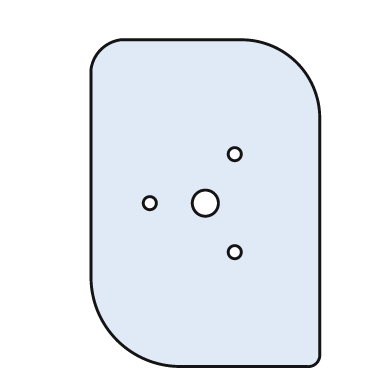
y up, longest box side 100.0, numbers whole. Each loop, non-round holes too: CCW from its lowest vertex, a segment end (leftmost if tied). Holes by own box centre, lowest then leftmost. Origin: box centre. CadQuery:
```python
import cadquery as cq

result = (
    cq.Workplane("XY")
    .moveTo(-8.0, -50.0)
    .lineTo(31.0, -50.0)
    .threePointArc((34.0, -49.0), (35.0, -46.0))
    .lineTo(35.0, 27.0)
    .threePointArc((28.0, 43.0), (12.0, 50.0))
    .lineTo(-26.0, 50.0)
    .threePointArc((-32.0, 47.0), (-35.0, 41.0))
    .lineTo(-35.0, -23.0)
    .threePointArc((-27.0, -42.0), (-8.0, -50.0))
    .close()
    .moveTo(9.0, -15.0)
    .circle(2.0)
    .moveTo(-17.0, 0.0)
    .circle(2.0)
    .moveTo(0.0, 0.0)
    .circle(4.0)
    .moveTo(9.0, 15.0)
    .circle(2.0)
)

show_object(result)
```